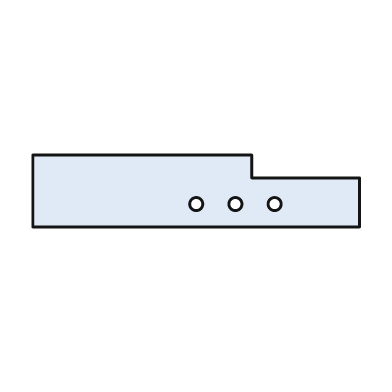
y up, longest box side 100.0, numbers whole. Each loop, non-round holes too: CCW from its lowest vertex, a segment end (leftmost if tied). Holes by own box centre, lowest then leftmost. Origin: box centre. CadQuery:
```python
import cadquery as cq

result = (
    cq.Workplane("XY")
    .moveTo(-50.0, -11.0)
    .lineTo(50.0, -11.0)
    .lineTo(50.0, 4.0)
    .lineTo(17.0, 4.0)
    .lineTo(17.0, 11.0)
    .lineTo(-50.0, 11.0)
    .close()
    .moveTo(0.0, -4.0)
    .circle(2.0)
    .moveTo(12.0, -4.0)
    .circle(2.0)
    .moveTo(24.0, -4.0)
    .circle(2.0)
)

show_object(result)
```